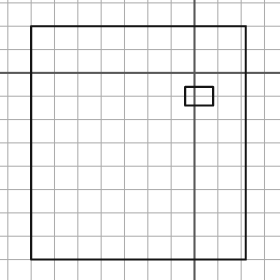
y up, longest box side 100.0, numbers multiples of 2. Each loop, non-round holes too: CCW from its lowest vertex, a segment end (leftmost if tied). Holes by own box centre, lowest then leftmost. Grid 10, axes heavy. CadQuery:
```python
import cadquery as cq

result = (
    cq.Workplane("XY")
    .moveTo(-70.0, -80.0)
    .lineTo(22.0, -80.0)
    .lineTo(22.0, 20.0)
    .lineTo(-70.0, 20.0)
    .close()
    .moveTo(-4.0, -14.0)
    .lineTo(8.0, -14.0)
    .lineTo(8.0, -6.0)
    .lineTo(-4.0, -6.0)
    .close()
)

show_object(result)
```